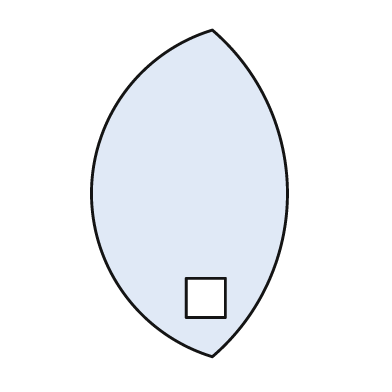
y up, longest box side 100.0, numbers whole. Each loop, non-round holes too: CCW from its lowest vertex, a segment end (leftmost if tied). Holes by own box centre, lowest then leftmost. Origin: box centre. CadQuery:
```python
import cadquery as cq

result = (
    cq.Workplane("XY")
    .moveTo(7.0, -50.0)
    .threePointArc((30.0, 0.0), (7.0, 50.0))
    .threePointArc((-30.0, 0.0), (7.0, -50.0))
    .close()
    .moveTo(-1.0, -38.0)
    .lineTo(11.0, -38.0)
    .lineTo(11.0, -26.0)
    .lineTo(-1.0, -26.0)
    .close()
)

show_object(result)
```